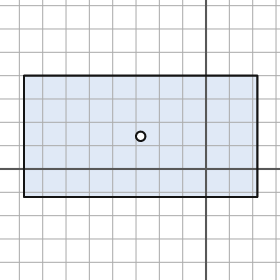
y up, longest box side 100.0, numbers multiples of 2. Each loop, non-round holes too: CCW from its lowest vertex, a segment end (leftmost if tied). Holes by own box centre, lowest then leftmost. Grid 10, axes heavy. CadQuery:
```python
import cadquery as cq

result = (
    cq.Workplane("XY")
    .moveTo(-78.0, -12.0)
    .lineTo(22.0, -12.0)
    .lineTo(22.0, 40.0)
    .lineTo(-78.0, 40.0)
    .close()
    .moveTo(-28.0, 14.0)
    .circle(2.0)
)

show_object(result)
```